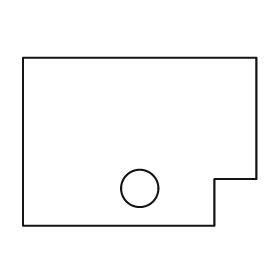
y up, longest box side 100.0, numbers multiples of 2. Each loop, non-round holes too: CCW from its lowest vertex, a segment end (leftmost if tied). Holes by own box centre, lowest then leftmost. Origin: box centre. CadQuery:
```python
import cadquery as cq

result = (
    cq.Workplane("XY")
    .moveTo(-50.0, -36.0)
    .lineTo(32.0, -36.0)
    .lineTo(32.0, -16.0)
    .lineTo(50.0, -16.0)
    .lineTo(50.0, 36.0)
    .lineTo(-50.0, 36.0)
    .close()
    .moveTo(0.0, -20.0)
    .circle(8.0)
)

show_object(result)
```